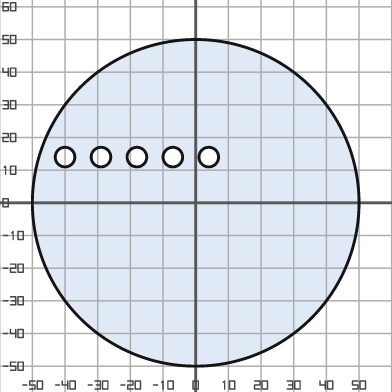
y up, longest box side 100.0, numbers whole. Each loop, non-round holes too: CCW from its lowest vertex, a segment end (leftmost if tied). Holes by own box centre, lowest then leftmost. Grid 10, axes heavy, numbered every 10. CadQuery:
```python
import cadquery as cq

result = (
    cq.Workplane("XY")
    .moveTo(0.0, 0.0)
    .circle(50.0)
    .moveTo(-40.0, 14.0)
    .circle(3.0)
    .moveTo(-29.0, 14.0)
    .circle(3.0)
    .moveTo(-18.0, 14.0)
    .circle(3.0)
    .moveTo(-7.0, 14.0)
    .circle(3.0)
    .moveTo(4.0, 14.0)
    .circle(3.0)
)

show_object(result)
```